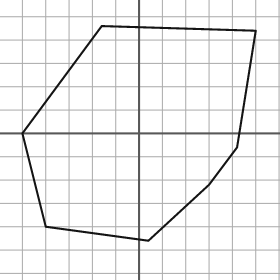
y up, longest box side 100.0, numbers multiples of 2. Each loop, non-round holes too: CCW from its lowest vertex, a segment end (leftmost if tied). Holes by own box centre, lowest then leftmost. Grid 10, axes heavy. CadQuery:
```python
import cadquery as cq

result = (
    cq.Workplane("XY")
    .moveTo(4.0, -46.0)
    .lineTo(30.0, -22.0)
    .lineTo(42.0, -6.0)
    .lineTo(50.0, 44.0)
    .lineTo(-16.0, 46.0)
    .lineTo(-50.0, 0.0)
    .lineTo(-40.0, -40.0)
    .close()
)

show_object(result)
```